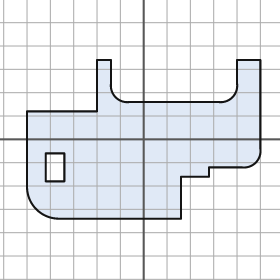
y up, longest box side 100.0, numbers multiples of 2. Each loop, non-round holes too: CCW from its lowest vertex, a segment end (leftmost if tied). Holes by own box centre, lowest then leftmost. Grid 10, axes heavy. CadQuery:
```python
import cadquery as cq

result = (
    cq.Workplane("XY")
    .moveTo(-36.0, -34.0)
    .lineTo(16.0, -34.0)
    .lineTo(16.0, -16.0)
    .lineTo(28.0, -16.0)
    .lineTo(28.0, -12.0)
    .lineTo(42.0, -12.0)
    .threePointArc((48.0, -10.0), (50.0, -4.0))
    .lineTo(50.0, 34.0)
    .lineTo(40.0, 34.0)
    .lineTo(40.0, 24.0)
    .threePointArc((38.0, 18.0), (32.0, 16.0))
    .lineTo(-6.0, 16.0)
    .threePointArc((-12.0, 18.0), (-14.0, 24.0))
    .lineTo(-14.0, 34.0)
    .lineTo(-20.0, 34.0)
    .lineTo(-20.0, 12.0)
    .lineTo(-50.0, 12.0)
    .lineTo(-50.0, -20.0)
    .threePointArc((-46.0, -30.0), (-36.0, -34.0))
    .close()
    .moveTo(-42.0, -18.0)
    .lineTo(-34.0, -18.0)
    .lineTo(-34.0, -6.0)
    .lineTo(-42.0, -6.0)
    .close()
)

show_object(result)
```